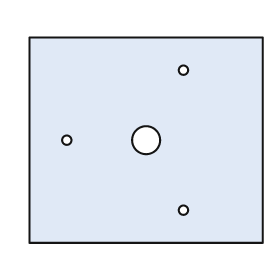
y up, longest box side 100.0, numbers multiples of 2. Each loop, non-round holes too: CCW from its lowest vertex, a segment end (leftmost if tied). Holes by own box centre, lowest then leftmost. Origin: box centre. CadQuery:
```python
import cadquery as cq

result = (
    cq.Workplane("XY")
    .moveTo(-50.0, -44.0)
    .lineTo(50.0, -44.0)
    .lineTo(50.0, 44.0)
    .lineTo(-50.0, 44.0)
    .close()
    .moveTo(16.0, -30.0)
    .circle(2.0)
    .moveTo(-34.0, 0.0)
    .circle(2.0)
    .moveTo(0.0, 0.0)
    .circle(6.0)
    .moveTo(16.0, 30.0)
    .circle(2.0)
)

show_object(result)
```